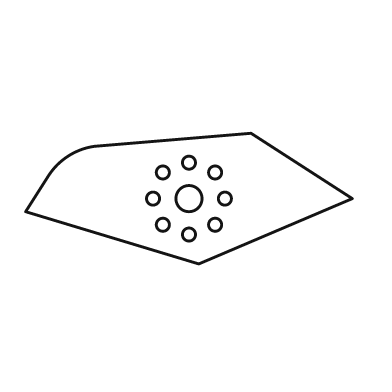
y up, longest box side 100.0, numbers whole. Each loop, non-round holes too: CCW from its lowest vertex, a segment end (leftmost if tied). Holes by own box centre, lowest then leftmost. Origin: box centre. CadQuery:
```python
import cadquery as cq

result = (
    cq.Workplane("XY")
    .moveTo(3.0, -20.0)
    .lineTo(50.0, 0.0)
    .lineTo(19.0, 20.0)
    .lineTo(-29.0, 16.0)
    .threePointArc((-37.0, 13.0), (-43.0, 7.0))
    .lineTo(-50.0, -4.0)
    .close()
    .moveTo(0.0, -11.0)
    .circle(2.0)
    .moveTo(-8.0, -8.0)
    .circle(2.0)
    .moveTo(8.0, -8.0)
    .circle(2.0)
    .moveTo(-11.0, 0.0)
    .circle(2.0)
    .moveTo(0.0, 0.0)
    .circle(4.0)
    .moveTo(11.0, 0.0)
    .circle(2.0)
    .moveTo(-8.0, 8.0)
    .circle(2.0)
    .moveTo(8.0, 8.0)
    .circle(2.0)
    .moveTo(0.0, 11.0)
    .circle(2.0)
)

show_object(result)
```